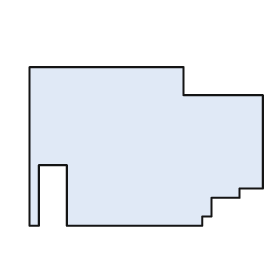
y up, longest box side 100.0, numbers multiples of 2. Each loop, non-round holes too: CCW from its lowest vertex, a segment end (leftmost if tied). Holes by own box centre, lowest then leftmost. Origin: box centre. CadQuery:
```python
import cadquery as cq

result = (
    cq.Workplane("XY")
    .moveTo(-50.0, -34.0)
    .lineTo(-46.0, -34.0)
    .lineTo(-46.0, -8.0)
    .lineTo(-34.0, -8.0)
    .lineTo(-34.0, -34.0)
    .lineTo(24.0, -34.0)
    .lineTo(24.0, -30.0)
    .lineTo(28.0, -30.0)
    .lineTo(28.0, -22.0)
    .lineTo(40.0, -22.0)
    .lineTo(40.0, -18.0)
    .lineTo(50.0, -18.0)
    .lineTo(50.0, 22.0)
    .lineTo(16.0, 22.0)
    .lineTo(16.0, 34.0)
    .lineTo(-50.0, 34.0)
    .close()
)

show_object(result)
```